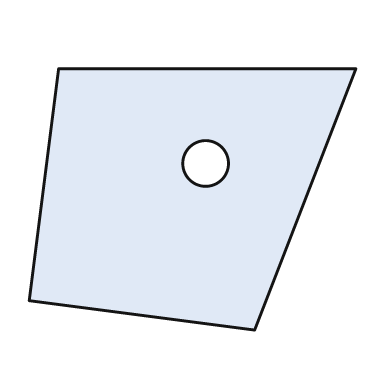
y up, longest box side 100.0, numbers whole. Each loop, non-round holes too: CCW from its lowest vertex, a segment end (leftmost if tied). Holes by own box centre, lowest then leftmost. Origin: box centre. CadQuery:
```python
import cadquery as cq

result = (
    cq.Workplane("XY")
    .moveTo(19.0, -40.0)
    .lineTo(50.0, 40.0)
    .lineTo(-41.0, 40.0)
    .lineTo(-50.0, -31.0)
    .close()
    .moveTo(4.0, 11.0)
    .circle(7.0)
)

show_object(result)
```